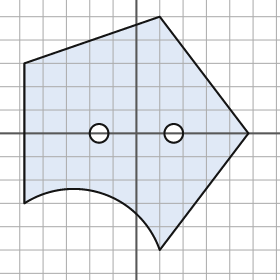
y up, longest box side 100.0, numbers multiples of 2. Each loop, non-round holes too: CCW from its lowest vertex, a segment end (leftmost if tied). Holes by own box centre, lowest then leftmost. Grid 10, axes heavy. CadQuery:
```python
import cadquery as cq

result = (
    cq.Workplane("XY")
    .moveTo(10.0, -50.0)
    .lineTo(48.0, 0.0)
    .lineTo(10.0, 50.0)
    .lineTo(-48.0, 30.0)
    .lineTo(-48.0, -30.0)
    .threePointArc((-14.0, -26.0), (10.0, -50.0))
    .close()
    .moveTo(-16.0, 0.0)
    .circle(4.0)
    .moveTo(16.0, 0.0)
    .circle(4.0)
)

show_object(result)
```